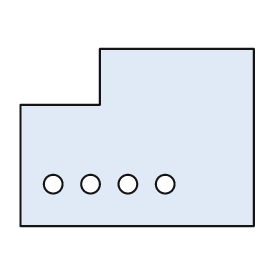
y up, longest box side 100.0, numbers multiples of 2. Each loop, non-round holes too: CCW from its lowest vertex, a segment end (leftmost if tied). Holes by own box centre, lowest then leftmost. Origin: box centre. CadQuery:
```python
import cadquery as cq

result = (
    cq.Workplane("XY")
    .moveTo(-50.0, -38.0)
    .lineTo(50.0, -38.0)
    .lineTo(50.0, 38.0)
    .lineTo(-16.0, 38.0)
    .lineTo(-16.0, 14.0)
    .lineTo(-50.0, 14.0)
    .close()
    .moveTo(-36.0, -20.0)
    .circle(4.0)
    .moveTo(-20.0, -20.0)
    .circle(4.0)
    .moveTo(-4.0, -20.0)
    .circle(4.0)
    .moveTo(12.0, -20.0)
    .circle(4.0)
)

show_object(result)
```